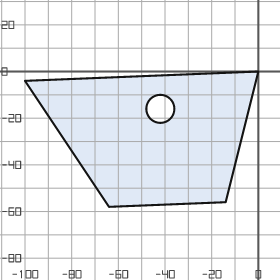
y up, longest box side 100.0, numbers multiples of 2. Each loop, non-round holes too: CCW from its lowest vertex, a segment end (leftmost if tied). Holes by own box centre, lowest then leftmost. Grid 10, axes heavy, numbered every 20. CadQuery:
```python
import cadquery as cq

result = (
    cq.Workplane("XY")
    .moveTo(-64.0, -58.0)
    .lineTo(-14.0, -56.0)
    .lineTo(0.0, 0.0)
    .lineTo(-100.0, -4.0)
    .close()
    .moveTo(-42.0, -16.0)
    .circle(6.0)
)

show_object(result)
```